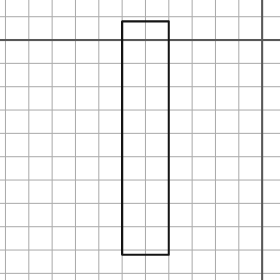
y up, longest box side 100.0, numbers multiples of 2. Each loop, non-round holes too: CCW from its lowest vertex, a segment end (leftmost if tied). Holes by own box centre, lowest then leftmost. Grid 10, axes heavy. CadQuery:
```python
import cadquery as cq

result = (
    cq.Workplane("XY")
    .moveTo(-60.0, -92.0)
    .lineTo(-40.0, -92.0)
    .lineTo(-40.0, 8.0)
    .lineTo(-60.0, 8.0)
    .close()
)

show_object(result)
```